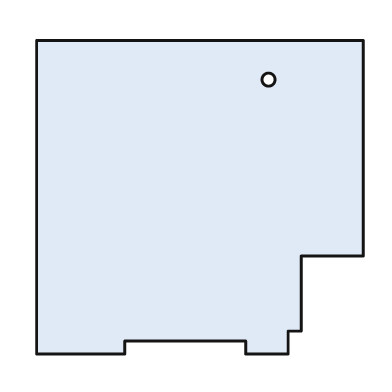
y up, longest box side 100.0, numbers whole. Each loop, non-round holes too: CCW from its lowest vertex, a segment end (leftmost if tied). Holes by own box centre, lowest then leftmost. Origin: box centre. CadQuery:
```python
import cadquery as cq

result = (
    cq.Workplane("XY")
    .moveTo(-50.0, -48.0)
    .lineTo(-23.0, -48.0)
    .lineTo(-23.0, -44.0)
    .lineTo(14.0, -44.0)
    .lineTo(14.0, -48.0)
    .lineTo(27.0, -48.0)
    .lineTo(27.0, -41.0)
    .lineTo(31.0, -41.0)
    .lineTo(31.0, -18.0)
    .lineTo(50.0, -18.0)
    .lineTo(50.0, 48.0)
    .lineTo(-50.0, 48.0)
    .close()
    .moveTo(21.0, 36.0)
    .circle(2.0)
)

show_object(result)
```